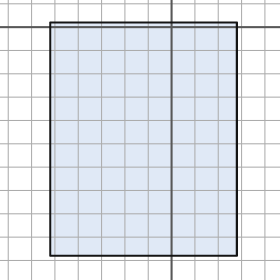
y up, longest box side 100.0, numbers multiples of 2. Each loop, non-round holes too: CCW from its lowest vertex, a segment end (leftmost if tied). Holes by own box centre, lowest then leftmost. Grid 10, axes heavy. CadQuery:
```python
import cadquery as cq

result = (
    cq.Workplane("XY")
    .moveTo(-52.0, -98.0)
    .lineTo(28.0, -98.0)
    .lineTo(28.0, 2.0)
    .lineTo(-52.0, 2.0)
    .close()
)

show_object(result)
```